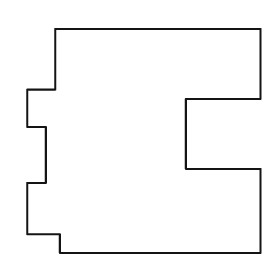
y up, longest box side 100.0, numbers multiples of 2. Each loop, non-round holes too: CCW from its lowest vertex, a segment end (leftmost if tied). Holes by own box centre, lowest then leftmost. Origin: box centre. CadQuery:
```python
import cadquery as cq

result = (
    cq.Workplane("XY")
    .moveTo(-36.0, -48.0)
    .lineTo(50.0, -48.0)
    .lineTo(50.0, -12.0)
    .lineTo(18.0, -12.0)
    .lineTo(18.0, 18.0)
    .lineTo(50.0, 18.0)
    .lineTo(50.0, 48.0)
    .lineTo(-38.0, 48.0)
    .lineTo(-38.0, 22.0)
    .lineTo(-50.0, 22.0)
    .lineTo(-50.0, 6.0)
    .lineTo(-42.0, 6.0)
    .lineTo(-42.0, -18.0)
    .lineTo(-50.0, -18.0)
    .lineTo(-50.0, -40.0)
    .lineTo(-36.0, -40.0)
    .close()
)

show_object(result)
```